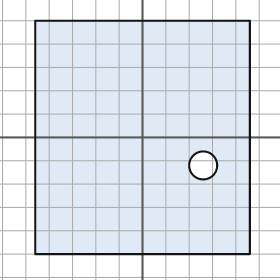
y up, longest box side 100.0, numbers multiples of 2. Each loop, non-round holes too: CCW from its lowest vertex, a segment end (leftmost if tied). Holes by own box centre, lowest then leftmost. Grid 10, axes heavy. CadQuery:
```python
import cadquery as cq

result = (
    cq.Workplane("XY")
    .moveTo(-46.0, -50.0)
    .lineTo(46.0, -50.0)
    .lineTo(46.0, 50.0)
    .lineTo(-46.0, 50.0)
    .close()
    .moveTo(26.0, -12.0)
    .circle(6.0)
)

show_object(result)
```